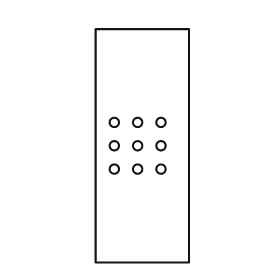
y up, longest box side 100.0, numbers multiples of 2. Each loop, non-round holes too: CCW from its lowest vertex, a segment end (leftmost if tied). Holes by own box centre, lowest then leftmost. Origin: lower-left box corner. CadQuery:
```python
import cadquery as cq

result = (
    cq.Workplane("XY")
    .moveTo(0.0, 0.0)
    .lineTo(40.0, 0.0)
    .lineTo(40.0, 100.0)
    .lineTo(0.0, 100.0)
    .close()
    .moveTo(8.0, 40.0)
    .circle(2.0)
    .moveTo(18.0, 40.0)
    .circle(2.0)
    .moveTo(28.0, 40.0)
    .circle(2.0)
    .moveTo(8.0, 50.0)
    .circle(2.0)
    .moveTo(18.0, 50.0)
    .circle(2.0)
    .moveTo(28.0, 50.0)
    .circle(2.0)
    .moveTo(8.0, 60.0)
    .circle(2.0)
    .moveTo(18.0, 60.0)
    .circle(2.0)
    .moveTo(28.0, 60.0)
    .circle(2.0)
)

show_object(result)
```